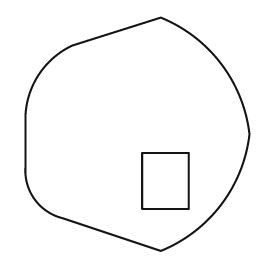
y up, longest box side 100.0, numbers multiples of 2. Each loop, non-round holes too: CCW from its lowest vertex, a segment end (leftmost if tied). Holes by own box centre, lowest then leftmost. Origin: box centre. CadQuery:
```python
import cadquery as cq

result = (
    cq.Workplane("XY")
    .moveTo(10.0, -50.0)
    .threePointArc((36.0, -30.0), (48.0, 0.0))
    .threePointArc((36.0, 30.0), (10.0, 50.0))
    .lineTo(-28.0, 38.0)
    .threePointArc((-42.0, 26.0), (-48.0, 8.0))
    .lineTo(-48.0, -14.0)
    .threePointArc((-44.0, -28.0), (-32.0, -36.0))
    .close()
    .moveTo(2.0, -32.0)
    .lineTo(22.0, -32.0)
    .lineTo(22.0, -8.0)
    .lineTo(2.0, -8.0)
    .close()
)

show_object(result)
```